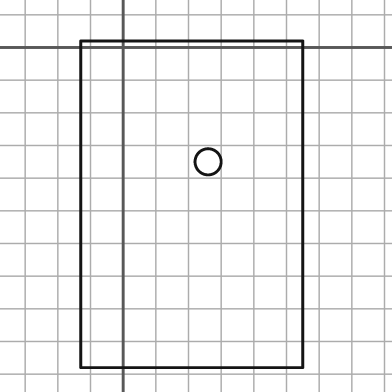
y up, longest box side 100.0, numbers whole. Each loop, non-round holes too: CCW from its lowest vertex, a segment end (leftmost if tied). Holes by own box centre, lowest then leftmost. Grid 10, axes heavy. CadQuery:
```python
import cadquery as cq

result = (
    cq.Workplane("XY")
    .moveTo(-13.0, -98.0)
    .lineTo(55.0, -98.0)
    .lineTo(55.0, 2.0)
    .lineTo(-13.0, 2.0)
    .close()
    .moveTo(26.0, -35.0)
    .circle(4.0)
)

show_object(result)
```